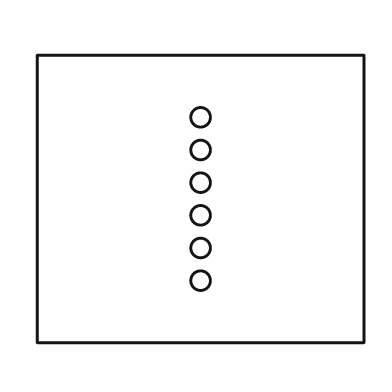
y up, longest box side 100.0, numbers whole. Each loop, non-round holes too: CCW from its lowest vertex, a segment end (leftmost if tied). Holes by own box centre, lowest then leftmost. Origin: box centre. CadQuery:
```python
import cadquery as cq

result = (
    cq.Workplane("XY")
    .moveTo(-50.0, -44.0)
    .lineTo(50.0, -44.0)
    .lineTo(50.0, 44.0)
    .lineTo(-50.0, 44.0)
    .close()
    .moveTo(0.0, -25.0)
    .circle(3.0)
    .moveTo(0.0, -15.0)
    .circle(3.0)
    .moveTo(0.0, -5.0)
    .circle(3.0)
    .moveTo(0.0, 5.0)
    .circle(3.0)
    .moveTo(0.0, 15.0)
    .circle(3.0)
    .moveTo(0.0, 25.0)
    .circle(3.0)
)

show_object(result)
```